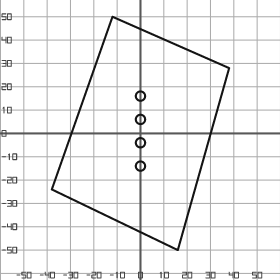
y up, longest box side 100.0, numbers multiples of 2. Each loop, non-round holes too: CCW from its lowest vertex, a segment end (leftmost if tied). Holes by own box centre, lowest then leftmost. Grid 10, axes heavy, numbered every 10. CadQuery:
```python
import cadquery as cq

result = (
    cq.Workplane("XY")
    .moveTo(16.0, -50.0)
    .lineTo(38.0, 28.0)
    .lineTo(-12.0, 50.0)
    .lineTo(-38.0, -24.0)
    .close()
    .moveTo(0.0, -14.0)
    .circle(2.0)
    .moveTo(0.0, -4.0)
    .circle(2.0)
    .moveTo(0.0, 6.0)
    .circle(2.0)
    .moveTo(0.0, 16.0)
    .circle(2.0)
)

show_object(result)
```